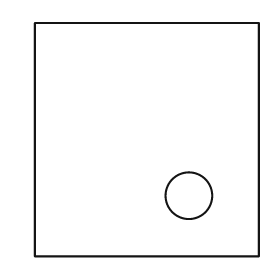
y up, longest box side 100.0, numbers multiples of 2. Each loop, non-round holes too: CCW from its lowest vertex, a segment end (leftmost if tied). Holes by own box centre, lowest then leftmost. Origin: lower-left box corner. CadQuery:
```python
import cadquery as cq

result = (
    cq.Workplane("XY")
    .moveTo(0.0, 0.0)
    .lineTo(96.0, 0.0)
    .lineTo(96.0, 100.0)
    .lineTo(0.0, 100.0)
    .close()
    .moveTo(66.0, 26.0)
    .circle(10.0)
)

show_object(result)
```